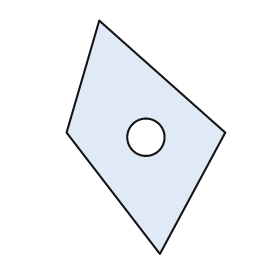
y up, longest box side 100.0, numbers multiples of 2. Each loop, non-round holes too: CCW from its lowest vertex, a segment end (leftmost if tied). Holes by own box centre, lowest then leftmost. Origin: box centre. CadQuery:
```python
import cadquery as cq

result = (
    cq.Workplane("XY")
    .moveTo(6.0, -50.0)
    .lineTo(34.0, 2.0)
    .lineTo(-20.0, 50.0)
    .lineTo(-34.0, 2.0)
    .close()
    .moveTo(0.0, 0.0)
    .circle(8.0)
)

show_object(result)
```